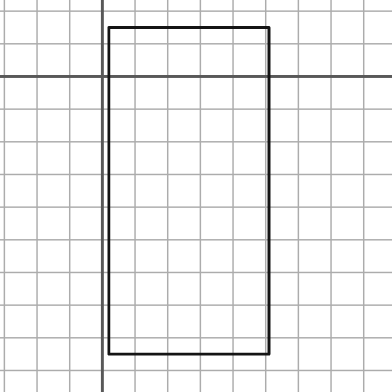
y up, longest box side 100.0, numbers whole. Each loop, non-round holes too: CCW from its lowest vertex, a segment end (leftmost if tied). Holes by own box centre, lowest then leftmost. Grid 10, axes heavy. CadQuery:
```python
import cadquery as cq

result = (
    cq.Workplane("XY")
    .moveTo(2.0, -85.0)
    .lineTo(51.0, -85.0)
    .lineTo(51.0, 15.0)
    .lineTo(2.0, 15.0)
    .close()
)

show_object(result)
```